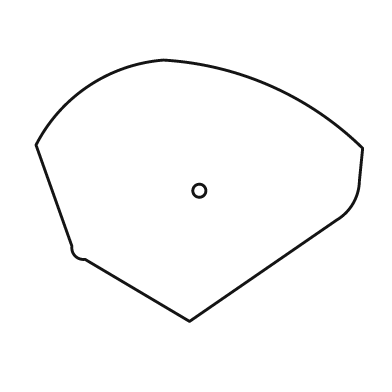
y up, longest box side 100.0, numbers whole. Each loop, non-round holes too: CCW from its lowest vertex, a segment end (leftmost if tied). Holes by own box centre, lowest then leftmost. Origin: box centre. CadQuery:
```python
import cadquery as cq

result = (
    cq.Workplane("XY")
    .moveTo(-3.0, -40.0)
    .lineTo(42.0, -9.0)
    .threePointArc((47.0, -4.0), (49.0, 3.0))
    .lineTo(50.0, 13.0)
    .threePointArc((22.0, 32.0), (-11.0, 40.0))
    .threePointArc((-34.0, 32.0), (-50.0, 14.0))
    .lineTo(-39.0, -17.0)
    .threePointArc((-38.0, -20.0), (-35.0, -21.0))
    .close()
    .moveTo(0.0, 0.0)
    .circle(2.0)
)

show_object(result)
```